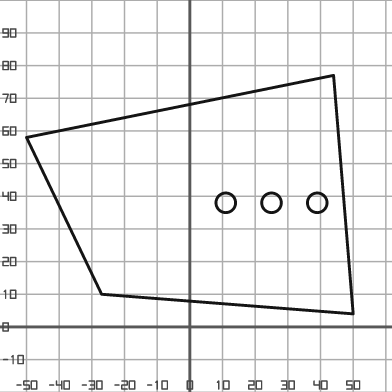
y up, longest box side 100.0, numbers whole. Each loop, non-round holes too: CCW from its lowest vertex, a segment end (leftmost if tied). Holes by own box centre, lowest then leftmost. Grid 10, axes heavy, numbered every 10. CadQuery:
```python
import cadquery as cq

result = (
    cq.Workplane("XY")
    .moveTo(50.0, 4.0)
    .lineTo(44.0, 77.0)
    .lineTo(-50.0, 58.0)
    .lineTo(-27.0, 10.0)
    .close()
    .moveTo(11.0, 38.0)
    .circle(3.0)
    .moveTo(25.0, 38.0)
    .circle(3.0)
    .moveTo(39.0, 38.0)
    .circle(3.0)
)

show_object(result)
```